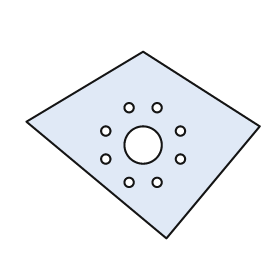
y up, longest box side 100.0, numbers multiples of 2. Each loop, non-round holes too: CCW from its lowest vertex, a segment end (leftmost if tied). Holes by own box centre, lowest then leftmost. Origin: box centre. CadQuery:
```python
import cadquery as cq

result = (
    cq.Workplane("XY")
    .moveTo(10.0, -40.0)
    .lineTo(50.0, 8.0)
    .lineTo(0.0, 40.0)
    .lineTo(-50.0, 10.0)
    .close()
    .moveTo(-6.0, -16.0)
    .circle(2.0)
    .moveTo(6.0, -16.0)
    .circle(2.0)
    .moveTo(-16.0, -6.0)
    .circle(2.0)
    .moveTo(16.0, -6.0)
    .circle(2.0)
    .moveTo(0.0, 0.0)
    .circle(8.0)
    .moveTo(-16.0, 6.0)
    .circle(2.0)
    .moveTo(16.0, 6.0)
    .circle(2.0)
    .moveTo(-6.0, 16.0)
    .circle(2.0)
    .moveTo(6.0, 16.0)
    .circle(2.0)
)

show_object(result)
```